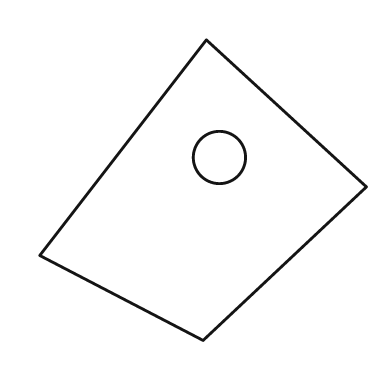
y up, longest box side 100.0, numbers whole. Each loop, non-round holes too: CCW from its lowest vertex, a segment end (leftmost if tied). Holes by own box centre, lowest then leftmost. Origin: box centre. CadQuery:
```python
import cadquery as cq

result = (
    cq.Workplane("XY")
    .moveTo(0.0, -46.0)
    .lineTo(50.0, 1.0)
    .lineTo(1.0, 46.0)
    .lineTo(-50.0, -20.0)
    .close()
    .moveTo(5.0, 10.0)
    .circle(8.0)
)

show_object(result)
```